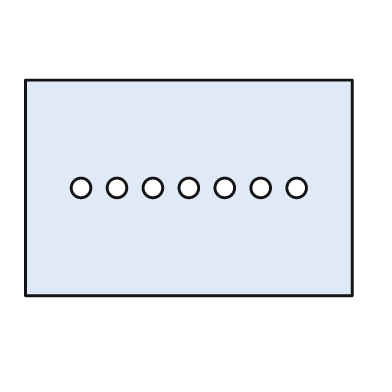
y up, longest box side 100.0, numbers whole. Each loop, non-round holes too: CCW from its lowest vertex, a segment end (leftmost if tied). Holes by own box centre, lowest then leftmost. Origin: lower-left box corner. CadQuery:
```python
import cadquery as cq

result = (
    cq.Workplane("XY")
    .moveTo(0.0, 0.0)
    .lineTo(100.0, 0.0)
    .lineTo(100.0, 66.0)
    .lineTo(0.0, 66.0)
    .close()
    .moveTo(17.0, 33.0)
    .circle(3.0)
    .moveTo(28.0, 33.0)
    .circle(3.0)
    .moveTo(39.0, 33.0)
    .circle(3.0)
    .moveTo(50.0, 33.0)
    .circle(3.0)
    .moveTo(61.0, 33.0)
    .circle(3.0)
    .moveTo(72.0, 33.0)
    .circle(3.0)
    .moveTo(83.0, 33.0)
    .circle(3.0)
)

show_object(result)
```